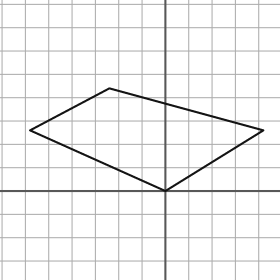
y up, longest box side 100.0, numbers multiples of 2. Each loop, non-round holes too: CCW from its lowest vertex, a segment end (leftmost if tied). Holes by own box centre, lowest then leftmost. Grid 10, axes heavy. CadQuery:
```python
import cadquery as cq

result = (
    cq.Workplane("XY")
    .moveTo(0.0, 0.0)
    .lineTo(42.0, 26.0)
    .lineTo(-24.0, 44.0)
    .lineTo(-58.0, 26.0)
    .close()
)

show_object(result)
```